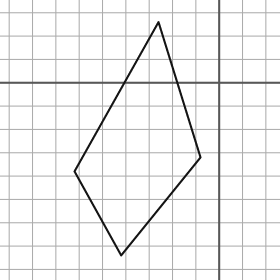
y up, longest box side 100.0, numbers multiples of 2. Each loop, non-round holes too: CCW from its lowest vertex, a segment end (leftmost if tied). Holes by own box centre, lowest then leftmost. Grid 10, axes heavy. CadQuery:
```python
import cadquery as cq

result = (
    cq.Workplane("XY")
    .moveTo(-42.0, -74.0)
    .lineTo(-8.0, -32.0)
    .lineTo(-26.0, 26.0)
    .lineTo(-62.0, -38.0)
    .close()
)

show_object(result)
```